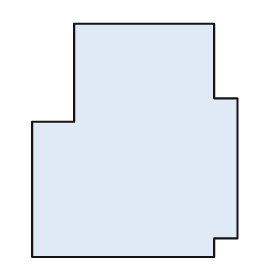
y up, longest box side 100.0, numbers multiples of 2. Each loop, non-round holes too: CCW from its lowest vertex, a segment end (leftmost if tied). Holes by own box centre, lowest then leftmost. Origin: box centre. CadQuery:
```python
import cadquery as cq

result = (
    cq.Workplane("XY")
    .moveTo(-44.0, -50.0)
    .lineTo(34.0, -50.0)
    .lineTo(34.0, -42.0)
    .lineTo(44.0, -42.0)
    .lineTo(44.0, 18.0)
    .lineTo(34.0, 18.0)
    .lineTo(34.0, 50.0)
    .lineTo(-26.0, 50.0)
    .lineTo(-26.0, 8.0)
    .lineTo(-44.0, 8.0)
    .close()
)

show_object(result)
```